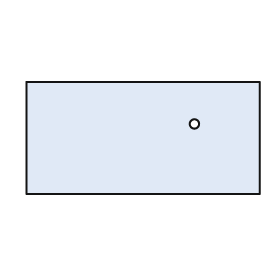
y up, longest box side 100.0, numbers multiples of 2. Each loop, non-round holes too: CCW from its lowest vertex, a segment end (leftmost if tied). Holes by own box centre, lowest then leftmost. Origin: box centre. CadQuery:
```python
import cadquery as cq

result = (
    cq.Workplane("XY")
    .moveTo(-50.0, -24.0)
    .lineTo(50.0, -24.0)
    .lineTo(50.0, 24.0)
    .lineTo(-50.0, 24.0)
    .close()
    .moveTo(22.0, 6.0)
    .circle(2.0)
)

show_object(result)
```